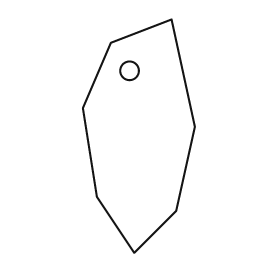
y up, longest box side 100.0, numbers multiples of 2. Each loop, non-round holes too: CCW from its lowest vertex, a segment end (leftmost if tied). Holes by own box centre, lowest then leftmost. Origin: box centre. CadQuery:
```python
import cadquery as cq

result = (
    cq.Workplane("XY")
    .moveTo(-2.0, -50.0)
    .lineTo(16.0, -32.0)
    .lineTo(24.0, 4.0)
    .lineTo(14.0, 50.0)
    .lineTo(-12.0, 40.0)
    .lineTo(-24.0, 12.0)
    .lineTo(-18.0, -26.0)
    .close()
    .moveTo(-4.0, 28.0)
    .circle(4.0)
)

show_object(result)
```